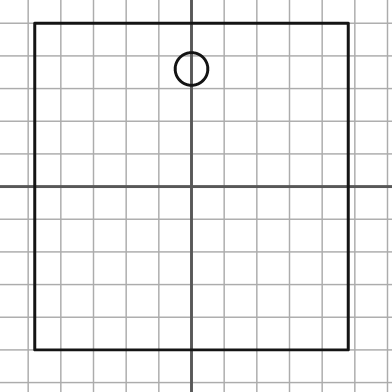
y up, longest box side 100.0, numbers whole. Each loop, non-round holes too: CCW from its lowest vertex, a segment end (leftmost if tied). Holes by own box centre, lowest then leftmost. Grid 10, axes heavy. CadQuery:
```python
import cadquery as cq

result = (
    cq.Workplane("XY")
    .moveTo(-48.0, -50.0)
    .lineTo(48.0, -50.0)
    .lineTo(48.0, 50.0)
    .lineTo(-48.0, 50.0)
    .close()
    .moveTo(0.0, 36.0)
    .circle(5.0)
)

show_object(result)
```